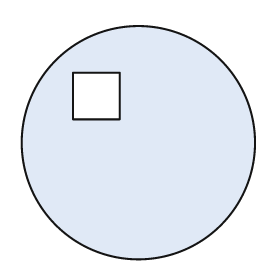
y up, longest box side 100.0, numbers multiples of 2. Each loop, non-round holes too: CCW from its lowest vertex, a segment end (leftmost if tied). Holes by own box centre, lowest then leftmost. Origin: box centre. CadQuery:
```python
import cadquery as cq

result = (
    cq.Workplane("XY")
    .moveTo(0.0, 0.0)
    .circle(50.0)
    .moveTo(-28.0, 10.0)
    .lineTo(-8.0, 10.0)
    .lineTo(-8.0, 30.0)
    .lineTo(-28.0, 30.0)
    .close()
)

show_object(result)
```